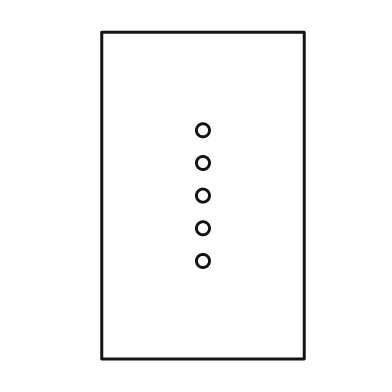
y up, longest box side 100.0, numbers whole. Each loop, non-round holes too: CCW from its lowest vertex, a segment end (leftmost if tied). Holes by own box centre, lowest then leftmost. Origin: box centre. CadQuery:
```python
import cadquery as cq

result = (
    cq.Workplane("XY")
    .moveTo(-31.0, -50.0)
    .lineTo(31.0, -50.0)
    .lineTo(31.0, 50.0)
    .lineTo(-31.0, 50.0)
    .close()
    .moveTo(0.0, -20.0)
    .circle(2.0)
    .moveTo(0.0, -10.0)
    .circle(2.0)
    .moveTo(0.0, 0.0)
    .circle(2.0)
    .moveTo(0.0, 10.0)
    .circle(2.0)
    .moveTo(0.0, 20.0)
    .circle(2.0)
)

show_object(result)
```